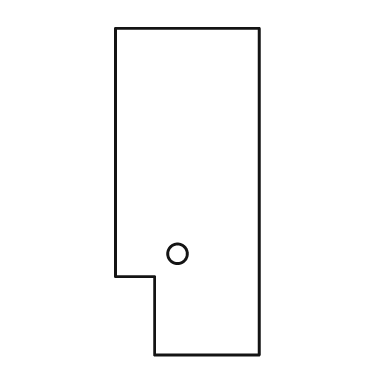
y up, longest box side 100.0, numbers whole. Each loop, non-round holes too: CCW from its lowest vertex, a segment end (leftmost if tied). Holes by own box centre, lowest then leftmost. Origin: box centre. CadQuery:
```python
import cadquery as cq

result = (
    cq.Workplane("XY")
    .moveTo(-10.0, -50.0)
    .lineTo(22.0, -50.0)
    .lineTo(22.0, 50.0)
    .lineTo(-22.0, 50.0)
    .lineTo(-22.0, -26.0)
    .lineTo(-10.0, -26.0)
    .close()
    .moveTo(-3.0, -19.0)
    .circle(3.0)
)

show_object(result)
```